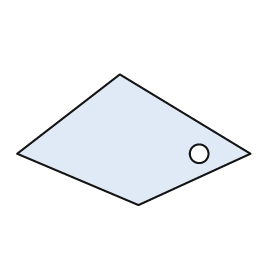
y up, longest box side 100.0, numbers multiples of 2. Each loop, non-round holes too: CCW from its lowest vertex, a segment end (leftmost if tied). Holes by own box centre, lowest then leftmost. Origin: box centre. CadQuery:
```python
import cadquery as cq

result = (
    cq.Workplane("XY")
    .moveTo(2.0, -28.0)
    .lineTo(50.0, -6.0)
    .lineTo(-6.0, 28.0)
    .lineTo(-50.0, -6.0)
    .close()
    .moveTo(28.0, -6.0)
    .circle(4.0)
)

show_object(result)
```